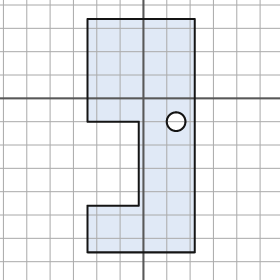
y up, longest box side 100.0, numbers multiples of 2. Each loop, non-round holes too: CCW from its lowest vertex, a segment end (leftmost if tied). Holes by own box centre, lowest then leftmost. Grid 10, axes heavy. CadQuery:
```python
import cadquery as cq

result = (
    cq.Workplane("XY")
    .moveTo(-24.0, -66.0)
    .lineTo(22.0, -66.0)
    .lineTo(22.0, 34.0)
    .lineTo(-24.0, 34.0)
    .lineTo(-24.0, -10.0)
    .lineTo(-2.0, -10.0)
    .lineTo(-2.0, -46.0)
    .lineTo(-24.0, -46.0)
    .close()
    .moveTo(14.0, -10.0)
    .circle(4.0)
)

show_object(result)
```